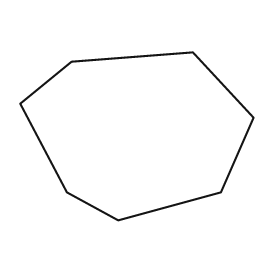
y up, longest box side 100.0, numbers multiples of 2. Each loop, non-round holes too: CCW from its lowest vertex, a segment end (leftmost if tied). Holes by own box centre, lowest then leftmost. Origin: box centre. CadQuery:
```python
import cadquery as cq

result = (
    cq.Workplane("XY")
    .moveTo(-8.0, -36.0)
    .lineTo(36.0, -24.0)
    .lineTo(50.0, 8.0)
    .lineTo(24.0, 36.0)
    .lineTo(-28.0, 32.0)
    .lineTo(-50.0, 14.0)
    .lineTo(-30.0, -24.0)
    .close()
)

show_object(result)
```